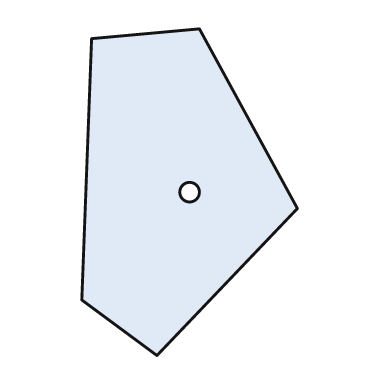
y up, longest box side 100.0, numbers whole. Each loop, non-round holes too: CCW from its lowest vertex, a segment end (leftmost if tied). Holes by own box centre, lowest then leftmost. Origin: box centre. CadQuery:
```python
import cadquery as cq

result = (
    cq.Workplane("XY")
    .moveTo(-10.0, -50.0)
    .lineTo(33.0, -5.0)
    .lineTo(3.0, 50.0)
    .lineTo(-30.0, 47.0)
    .lineTo(-33.0, -33.0)
    .close()
    .moveTo(0.0, 0.0)
    .circle(3.0)
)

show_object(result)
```